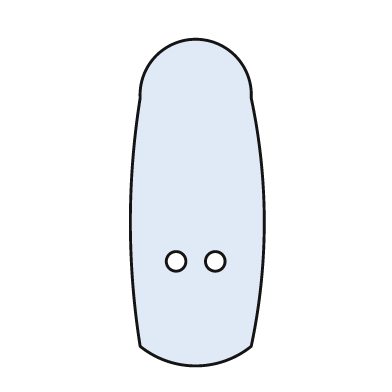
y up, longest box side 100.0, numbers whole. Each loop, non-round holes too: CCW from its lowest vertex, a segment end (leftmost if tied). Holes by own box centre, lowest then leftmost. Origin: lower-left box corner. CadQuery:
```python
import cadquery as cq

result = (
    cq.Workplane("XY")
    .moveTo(3.0, 6.0)
    .threePointArc((20.0, 0.0), (37.0, 6.0))
    .threePointArc((41.0, 44.0), (37.0, 82.0))
    .threePointArc((20.0, 100.0), (3.0, 82.0))
    .threePointArc((0.0, 44.0), (3.0, 6.0))
    .close()
    .moveTo(14.0, 32.0)
    .circle(3.0)
    .moveTo(26.0, 32.0)
    .circle(3.0)
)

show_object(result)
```